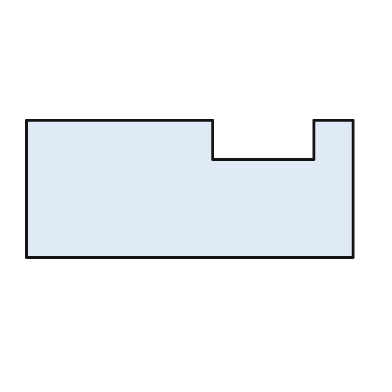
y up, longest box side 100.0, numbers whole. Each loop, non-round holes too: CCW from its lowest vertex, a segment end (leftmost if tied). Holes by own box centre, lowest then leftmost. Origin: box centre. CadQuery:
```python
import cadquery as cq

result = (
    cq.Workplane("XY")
    .moveTo(-50.0, -21.0)
    .lineTo(50.0, -21.0)
    .lineTo(50.0, 21.0)
    .lineTo(38.0, 21.0)
    .lineTo(38.0, 9.0)
    .lineTo(7.0, 9.0)
    .lineTo(7.0, 21.0)
    .lineTo(-50.0, 21.0)
    .close()
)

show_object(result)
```